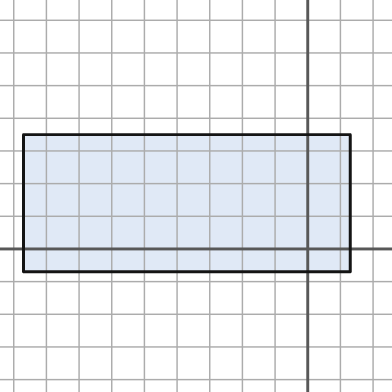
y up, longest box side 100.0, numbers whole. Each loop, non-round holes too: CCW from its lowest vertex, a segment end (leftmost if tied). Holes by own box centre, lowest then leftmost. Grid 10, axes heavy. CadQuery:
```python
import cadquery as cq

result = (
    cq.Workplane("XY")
    .moveTo(-87.0, -7.0)
    .lineTo(13.0, -7.0)
    .lineTo(13.0, 35.0)
    .lineTo(-87.0, 35.0)
    .close()
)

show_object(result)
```